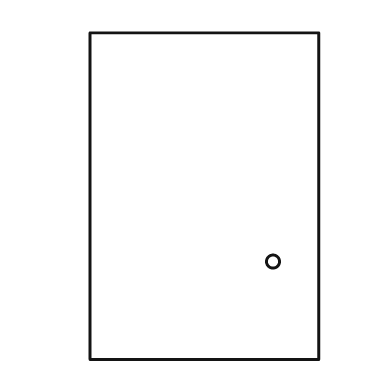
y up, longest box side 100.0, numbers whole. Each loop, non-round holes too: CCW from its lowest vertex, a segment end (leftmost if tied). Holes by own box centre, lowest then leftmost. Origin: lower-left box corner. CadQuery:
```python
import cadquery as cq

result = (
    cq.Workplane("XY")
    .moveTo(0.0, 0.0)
    .lineTo(70.0, 0.0)
    .lineTo(70.0, 100.0)
    .lineTo(0.0, 100.0)
    .close()
    .moveTo(56.0, 30.0)
    .circle(2.0)
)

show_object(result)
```